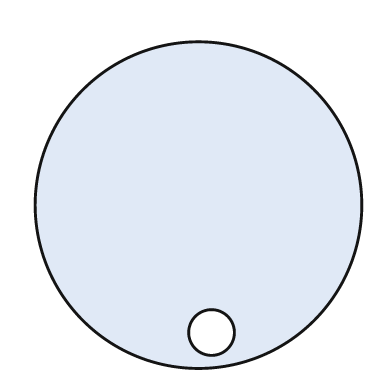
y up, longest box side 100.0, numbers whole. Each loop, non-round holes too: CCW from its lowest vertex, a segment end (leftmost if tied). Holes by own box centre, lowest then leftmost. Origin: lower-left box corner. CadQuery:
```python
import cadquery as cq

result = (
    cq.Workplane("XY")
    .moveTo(50.0, 50.0)
    .circle(50.0)
    .moveTo(54.0, 11.0)
    .circle(7.0)
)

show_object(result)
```